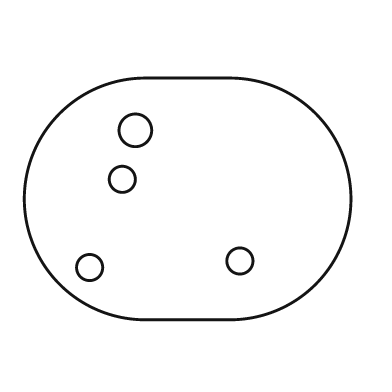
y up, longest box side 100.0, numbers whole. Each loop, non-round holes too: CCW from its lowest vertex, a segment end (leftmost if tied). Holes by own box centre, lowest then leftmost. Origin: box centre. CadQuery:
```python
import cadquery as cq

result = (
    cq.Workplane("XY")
    .moveTo(-13.0, -37.0)
    .lineTo(13.0, -37.0)
    .threePointArc((50.0, 0.0), (13.0, 37.0))
    .lineTo(-13.0, 37.0)
    .threePointArc((-50.0, 0.0), (-13.0, -37.0))
    .close()
    .moveTo(-30.0, -21.0)
    .circle(4.0)
    .moveTo(16.0, -19.0)
    .circle(4.0)
    .moveTo(-20.0, 6.0)
    .circle(4.0)
    .moveTo(-16.0, 21.0)
    .circle(5.0)
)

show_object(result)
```